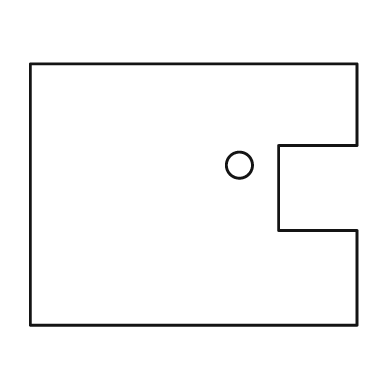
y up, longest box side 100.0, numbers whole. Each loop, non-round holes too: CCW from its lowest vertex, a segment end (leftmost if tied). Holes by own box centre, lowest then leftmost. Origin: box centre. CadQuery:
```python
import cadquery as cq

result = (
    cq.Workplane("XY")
    .moveTo(-50.0, -40.0)
    .lineTo(50.0, -40.0)
    .lineTo(50.0, -11.0)
    .lineTo(26.0, -11.0)
    .lineTo(26.0, 15.0)
    .lineTo(50.0, 15.0)
    .lineTo(50.0, 40.0)
    .lineTo(-50.0, 40.0)
    .close()
    .moveTo(14.0, 9.0)
    .circle(4.0)
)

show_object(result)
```